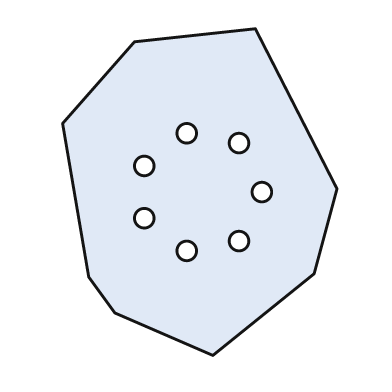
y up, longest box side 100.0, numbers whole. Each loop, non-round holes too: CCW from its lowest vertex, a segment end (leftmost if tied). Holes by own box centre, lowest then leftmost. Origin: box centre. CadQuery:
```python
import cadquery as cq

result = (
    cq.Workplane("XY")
    .moveTo(4.0, -50.0)
    .lineTo(35.0, -25.0)
    .lineTo(42.0, 1.0)
    .lineTo(17.0, 50.0)
    .lineTo(-20.0, 46.0)
    .lineTo(-42.0, 21.0)
    .lineTo(-34.0, -26.0)
    .lineTo(-26.0, -37.0)
    .close()
    .moveTo(-4.0, -18.0)
    .circle(3.0)
    .moveTo(12.0, -15.0)
    .circle(3.0)
    .moveTo(-17.0, -8.0)
    .circle(3.0)
    .moveTo(19.0, 0.0)
    .circle(3.0)
    .moveTo(-17.0, 8.0)
    .circle(3.0)
    .moveTo(12.0, 15.0)
    .circle(3.0)
    .moveTo(-4.0, 18.0)
    .circle(3.0)
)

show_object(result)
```